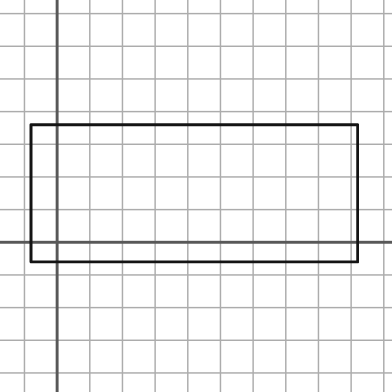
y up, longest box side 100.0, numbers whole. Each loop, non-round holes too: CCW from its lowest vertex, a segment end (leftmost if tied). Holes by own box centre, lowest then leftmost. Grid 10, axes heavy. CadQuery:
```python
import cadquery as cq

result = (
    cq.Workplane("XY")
    .moveTo(-8.0, -6.0)
    .lineTo(92.0, -6.0)
    .lineTo(92.0, 36.0)
    .lineTo(-8.0, 36.0)
    .close()
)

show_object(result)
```